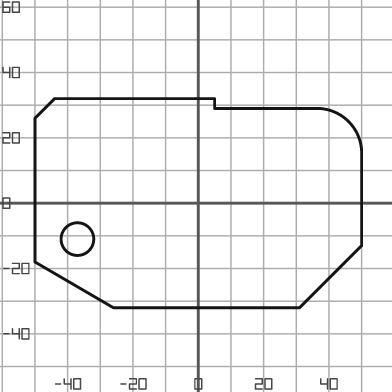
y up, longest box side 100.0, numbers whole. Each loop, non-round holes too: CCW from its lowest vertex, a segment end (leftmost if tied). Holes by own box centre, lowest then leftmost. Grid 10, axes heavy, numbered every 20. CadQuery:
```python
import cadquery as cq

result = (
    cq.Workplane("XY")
    .moveTo(-26.0, -32.0)
    .lineTo(31.0, -32.0)
    .lineTo(50.0, -13.0)
    .lineTo(50.0, 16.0)
    .threePointArc((46.0, 25.0), (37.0, 29.0))
    .lineTo(5.0, 29.0)
    .lineTo(5.0, 32.0)
    .lineTo(-44.0, 32.0)
    .lineTo(-50.0, 26.0)
    .lineTo(-50.0, -18.0)
    .close()
    .moveTo(-37.0, -11.0)
    .circle(5.0)
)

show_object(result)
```